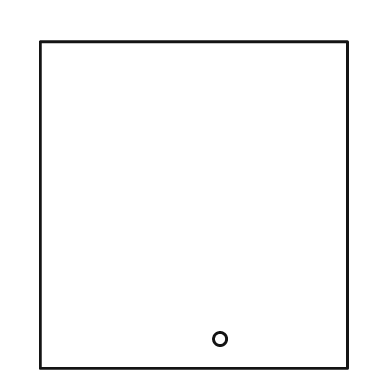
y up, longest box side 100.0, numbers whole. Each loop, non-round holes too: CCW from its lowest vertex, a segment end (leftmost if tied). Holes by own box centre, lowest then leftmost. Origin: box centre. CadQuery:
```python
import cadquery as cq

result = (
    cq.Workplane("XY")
    .moveTo(-47.0, -50.0)
    .lineTo(47.0, -50.0)
    .lineTo(47.0, 50.0)
    .lineTo(-47.0, 50.0)
    .close()
    .moveTo(8.0, -41.0)
    .circle(2.0)
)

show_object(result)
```